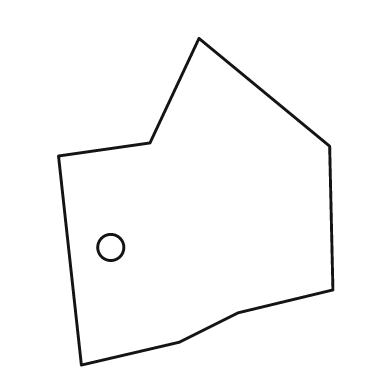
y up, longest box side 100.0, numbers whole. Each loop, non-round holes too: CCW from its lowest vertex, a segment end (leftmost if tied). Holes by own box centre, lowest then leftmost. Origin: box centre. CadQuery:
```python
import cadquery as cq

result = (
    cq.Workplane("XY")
    .moveTo(-35.0, -50.0)
    .lineTo(-5.0, -43.0)
    .lineTo(13.0, -34.0)
    .lineTo(42.0, -27.0)
    .lineTo(41.0, 17.0)
    .lineTo(1.0, 50.0)
    .lineTo(-14.0, 18.0)
    .lineTo(-42.0, 14.0)
    .close()
    .moveTo(-26.0, -14.0)
    .circle(4.0)
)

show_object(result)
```